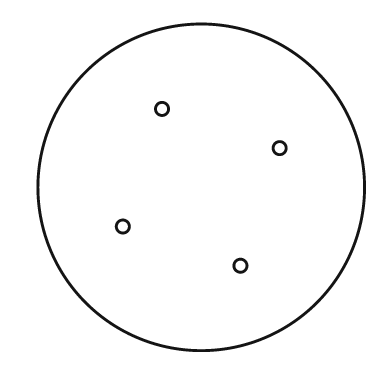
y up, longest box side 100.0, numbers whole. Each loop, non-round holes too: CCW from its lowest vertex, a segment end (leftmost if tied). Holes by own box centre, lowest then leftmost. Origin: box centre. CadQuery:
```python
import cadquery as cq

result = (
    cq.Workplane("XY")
    .moveTo(0.0, 0.0)
    .circle(50.0)
    .moveTo(12.0, -24.0)
    .circle(2.0)
    .moveTo(-24.0, -12.0)
    .circle(2.0)
    .moveTo(24.0, 12.0)
    .circle(2.0)
    .moveTo(-12.0, 24.0)
    .circle(2.0)
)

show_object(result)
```